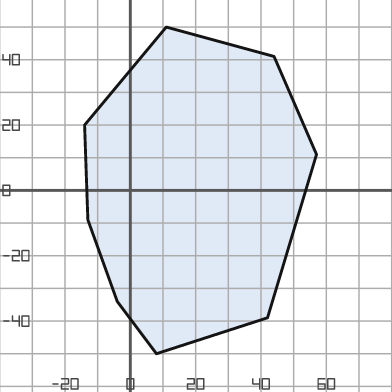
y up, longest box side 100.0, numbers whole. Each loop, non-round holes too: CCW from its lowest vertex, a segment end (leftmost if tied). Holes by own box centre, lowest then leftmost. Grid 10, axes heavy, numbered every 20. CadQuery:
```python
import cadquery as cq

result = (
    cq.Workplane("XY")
    .moveTo(8.0, -50.0)
    .lineTo(42.0, -39.0)
    .lineTo(57.0, 11.0)
    .lineTo(44.0, 41.0)
    .lineTo(11.0, 50.0)
    .lineTo(-14.0, 20.0)
    .lineTo(-13.0, -9.0)
    .lineTo(-4.0, -34.0)
    .close()
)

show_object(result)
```